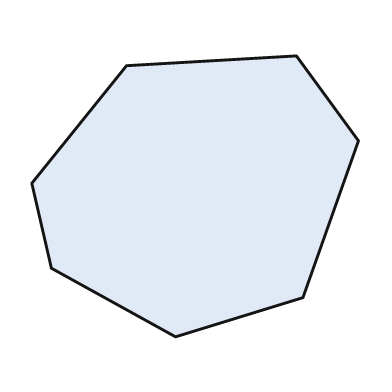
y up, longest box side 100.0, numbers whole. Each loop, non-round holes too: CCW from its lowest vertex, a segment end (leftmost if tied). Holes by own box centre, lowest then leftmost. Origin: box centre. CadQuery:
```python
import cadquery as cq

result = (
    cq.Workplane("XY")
    .moveTo(-6.0, -43.0)
    .lineTo(33.0, -31.0)
    .lineTo(50.0, 17.0)
    .lineTo(31.0, 43.0)
    .lineTo(-21.0, 40.0)
    .lineTo(-50.0, 4.0)
    .lineTo(-44.0, -22.0)
    .close()
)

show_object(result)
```